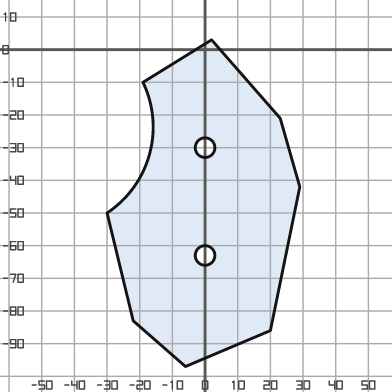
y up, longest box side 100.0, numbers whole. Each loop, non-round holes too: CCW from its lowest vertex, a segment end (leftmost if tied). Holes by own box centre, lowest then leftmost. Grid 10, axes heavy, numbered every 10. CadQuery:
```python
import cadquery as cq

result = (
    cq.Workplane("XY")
    .moveTo(-6.0, -97.0)
    .lineTo(20.0, -86.0)
    .lineTo(29.0, -42.0)
    .lineTo(23.0, -21.0)
    .lineTo(2.0, 3.0)
    .lineTo(-19.0, -10.0)
    .threePointArc((-17.0, -32.0), (-30.0, -50.0))
    .lineTo(-22.0, -83.0)
    .close()
    .moveTo(0.0, -63.0)
    .circle(3.0)
    .moveTo(0.0, -30.0)
    .circle(3.0)
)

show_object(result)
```